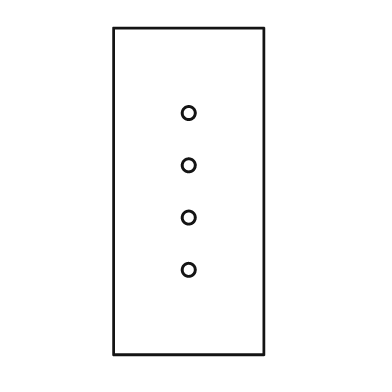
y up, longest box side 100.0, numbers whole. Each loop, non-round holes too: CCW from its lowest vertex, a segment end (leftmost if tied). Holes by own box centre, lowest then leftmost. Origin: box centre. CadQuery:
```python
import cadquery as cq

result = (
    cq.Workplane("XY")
    .moveTo(-23.0, -50.0)
    .lineTo(23.0, -50.0)
    .lineTo(23.0, 50.0)
    .lineTo(-23.0, 50.0)
    .close()
    .moveTo(0.0, -24.0)
    .circle(2.0)
    .moveTo(0.0, -8.0)
    .circle(2.0)
    .moveTo(0.0, 8.0)
    .circle(2.0)
    .moveTo(0.0, 24.0)
    .circle(2.0)
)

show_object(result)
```